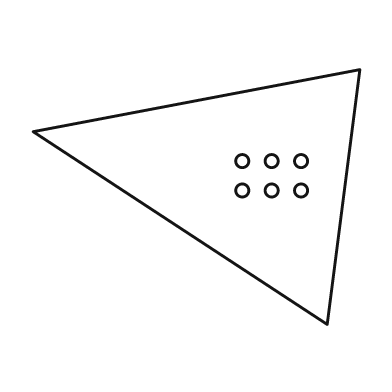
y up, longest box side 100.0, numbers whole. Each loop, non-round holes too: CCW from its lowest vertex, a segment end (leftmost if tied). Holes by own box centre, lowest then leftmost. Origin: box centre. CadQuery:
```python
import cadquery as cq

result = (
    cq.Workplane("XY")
    .moveTo(40.0, -39.0)
    .lineTo(50.0, 39.0)
    .lineTo(-50.0, 20.0)
    .close()
    .moveTo(14.0, 2.0)
    .circle(2.0)
    .moveTo(23.0, 2.0)
    .circle(2.0)
    .moveTo(32.0, 2.0)
    .circle(2.0)
    .moveTo(14.0, 11.0)
    .circle(2.0)
    .moveTo(23.0, 11.0)
    .circle(2.0)
    .moveTo(32.0, 11.0)
    .circle(2.0)
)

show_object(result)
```